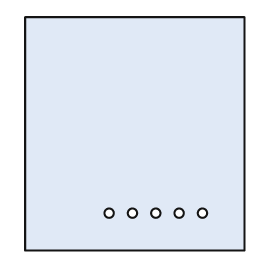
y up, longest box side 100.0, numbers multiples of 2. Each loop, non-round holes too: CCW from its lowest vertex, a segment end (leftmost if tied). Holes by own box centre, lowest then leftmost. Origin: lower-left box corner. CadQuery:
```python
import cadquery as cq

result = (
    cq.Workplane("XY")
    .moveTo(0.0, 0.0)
    .lineTo(94.0, 0.0)
    .lineTo(94.0, 100.0)
    .lineTo(0.0, 100.0)
    .close()
    .moveTo(36.0, 16.0)
    .circle(2.0)
    .moveTo(46.0, 16.0)
    .circle(2.0)
    .moveTo(56.0, 16.0)
    .circle(2.0)
    .moveTo(66.0, 16.0)
    .circle(2.0)
    .moveTo(76.0, 16.0)
    .circle(2.0)
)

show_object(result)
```